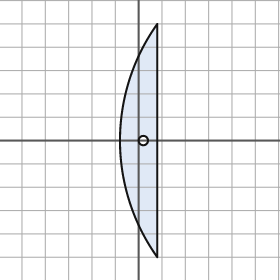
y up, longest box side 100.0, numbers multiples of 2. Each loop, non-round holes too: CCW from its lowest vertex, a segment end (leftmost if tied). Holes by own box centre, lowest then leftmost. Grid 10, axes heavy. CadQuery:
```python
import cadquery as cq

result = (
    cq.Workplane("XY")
    .moveTo(8.0, -50.0)
    .lineTo(8.0, 50.0)
    .threePointArc((-8.0, 0.0), (8.0, -50.0))
    .close()
    .moveTo(2.0, 0.0)
    .circle(2.0)
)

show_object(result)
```